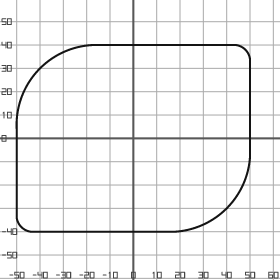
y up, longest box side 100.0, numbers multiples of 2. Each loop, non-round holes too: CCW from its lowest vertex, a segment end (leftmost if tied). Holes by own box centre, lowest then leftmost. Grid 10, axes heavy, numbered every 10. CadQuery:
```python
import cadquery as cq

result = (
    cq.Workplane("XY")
    .moveTo(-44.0, -40.0)
    .lineTo(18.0, -40.0)
    .threePointArc((40.0, -30.0), (50.0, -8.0))
    .lineTo(50.0, 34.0)
    .threePointArc((48.0, 38.0), (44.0, 40.0))
    .lineTo(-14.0, 40.0)
    .threePointArc((-40.0, 30.0), (-50.0, 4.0))
    .lineTo(-50.0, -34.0)
    .threePointArc((-48.0, -38.0), (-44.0, -40.0))
    .close()
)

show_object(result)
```